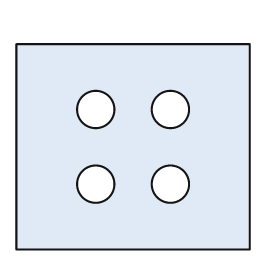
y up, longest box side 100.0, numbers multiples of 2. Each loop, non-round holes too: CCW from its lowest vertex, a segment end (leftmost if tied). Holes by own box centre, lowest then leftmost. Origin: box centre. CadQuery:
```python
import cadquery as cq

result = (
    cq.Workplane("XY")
    .moveTo(-50.0, -44.0)
    .lineTo(50.0, -44.0)
    .lineTo(50.0, 44.0)
    .lineTo(-50.0, 44.0)
    .close()
    .moveTo(-16.0, -16.0)
    .circle(8.0)
    .moveTo(16.0, -16.0)
    .circle(8.0)
    .moveTo(-16.0, 16.0)
    .circle(8.0)
    .moveTo(16.0, 16.0)
    .circle(8.0)
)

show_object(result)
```